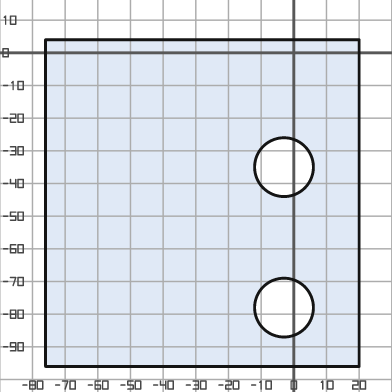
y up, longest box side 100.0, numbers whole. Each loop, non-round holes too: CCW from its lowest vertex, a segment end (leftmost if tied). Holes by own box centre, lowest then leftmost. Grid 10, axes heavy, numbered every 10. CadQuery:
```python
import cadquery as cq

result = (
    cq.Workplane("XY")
    .moveTo(-76.0, -96.0)
    .lineTo(20.0, -96.0)
    .lineTo(20.0, 4.0)
    .lineTo(-76.0, 4.0)
    .close()
    .moveTo(-3.0, -78.0)
    .circle(9.0)
    .moveTo(-3.0, -35.0)
    .circle(9.0)
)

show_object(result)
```